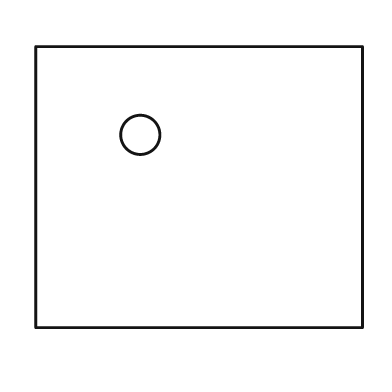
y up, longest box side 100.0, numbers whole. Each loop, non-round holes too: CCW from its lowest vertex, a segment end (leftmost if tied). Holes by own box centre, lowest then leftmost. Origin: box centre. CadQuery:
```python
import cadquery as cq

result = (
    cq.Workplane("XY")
    .moveTo(-50.0, -43.0)
    .lineTo(50.0, -43.0)
    .lineTo(50.0, 43.0)
    .lineTo(-50.0, 43.0)
    .close()
    .moveTo(-18.0, 16.0)
    .circle(6.0)
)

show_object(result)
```